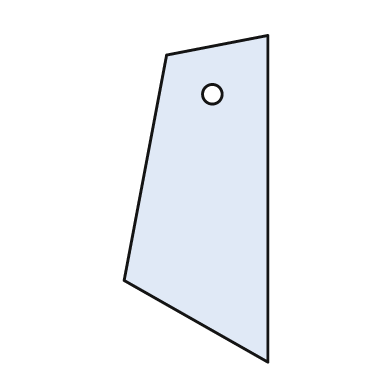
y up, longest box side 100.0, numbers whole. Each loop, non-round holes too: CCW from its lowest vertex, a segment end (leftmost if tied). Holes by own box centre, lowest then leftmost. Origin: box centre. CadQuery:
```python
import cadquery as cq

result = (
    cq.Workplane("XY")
    .moveTo(22.0, -50.0)
    .lineTo(22.0, 50.0)
    .lineTo(-9.0, 44.0)
    .lineTo(-22.0, -25.0)
    .close()
    .moveTo(5.0, 32.0)
    .circle(3.0)
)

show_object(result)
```